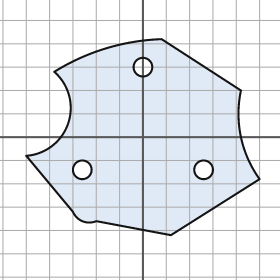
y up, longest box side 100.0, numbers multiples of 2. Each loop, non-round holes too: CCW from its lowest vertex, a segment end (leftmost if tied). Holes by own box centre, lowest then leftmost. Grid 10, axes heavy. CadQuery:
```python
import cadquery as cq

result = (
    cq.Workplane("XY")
    .moveTo(12.0, -42.0)
    .lineTo(50.0, -18.0)
    .threePointArc((42.0, 0.0), (42.0, 20.0))
    .lineTo(8.0, 42.0)
    .threePointArc((-16.0, 38.0), (-38.0, 28.0))
    .threePointArc((-32.0, 6.0), (-50.0, -8.0))
    .lineTo(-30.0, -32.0)
    .threePointArc((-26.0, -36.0), (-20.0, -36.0))
    .close()
    .moveTo(-26.0, -14.0)
    .circle(4.0)
    .moveTo(26.0, -14.0)
    .circle(4.0)
    .moveTo(0.0, 30.0)
    .circle(4.0)
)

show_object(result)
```